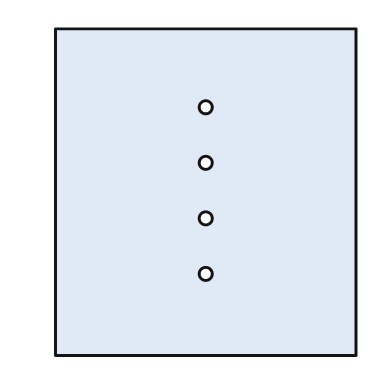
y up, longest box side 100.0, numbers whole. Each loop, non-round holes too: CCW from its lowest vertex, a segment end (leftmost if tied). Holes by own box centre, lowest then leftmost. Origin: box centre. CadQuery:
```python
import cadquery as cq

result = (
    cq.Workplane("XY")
    .moveTo(-46.0, -50.0)
    .lineTo(46.0, -50.0)
    .lineTo(46.0, 50.0)
    .lineTo(-46.0, 50.0)
    .close()
    .moveTo(0.0, -25.0)
    .circle(2.0)
    .moveTo(0.0, -8.0)
    .circle(2.0)
    .moveTo(0.0, 9.0)
    .circle(2.0)
    .moveTo(0.0, 26.0)
    .circle(2.0)
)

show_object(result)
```